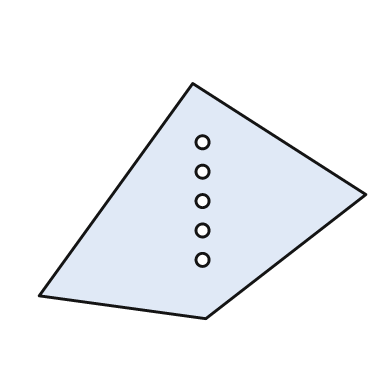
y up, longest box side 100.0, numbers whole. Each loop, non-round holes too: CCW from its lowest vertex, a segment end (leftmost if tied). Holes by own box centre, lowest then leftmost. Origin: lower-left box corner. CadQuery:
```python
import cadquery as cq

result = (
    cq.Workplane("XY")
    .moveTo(51.0, 0.0)
    .lineTo(100.0, 38.0)
    .lineTo(47.0, 72.0)
    .lineTo(0.0, 7.0)
    .close()
    .moveTo(50.0, 18.0)
    .circle(2.0)
    .moveTo(50.0, 27.0)
    .circle(2.0)
    .moveTo(50.0, 36.0)
    .circle(2.0)
    .moveTo(50.0, 45.0)
    .circle(2.0)
    .moveTo(50.0, 54.0)
    .circle(2.0)
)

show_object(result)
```